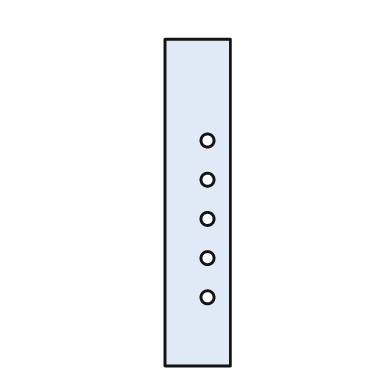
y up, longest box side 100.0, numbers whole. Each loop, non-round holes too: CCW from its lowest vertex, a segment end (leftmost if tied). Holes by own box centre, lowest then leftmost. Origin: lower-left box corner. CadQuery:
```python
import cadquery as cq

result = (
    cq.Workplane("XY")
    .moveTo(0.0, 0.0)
    .lineTo(20.0, 0.0)
    .lineTo(20.0, 100.0)
    .lineTo(0.0, 100.0)
    .close()
    .moveTo(13.0, 21.0)
    .circle(2.0)
    .moveTo(13.0, 33.0)
    .circle(2.0)
    .moveTo(13.0, 45.0)
    .circle(2.0)
    .moveTo(13.0, 57.0)
    .circle(2.0)
    .moveTo(13.0, 69.0)
    .circle(2.0)
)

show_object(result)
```